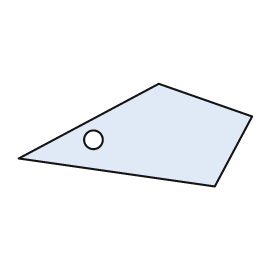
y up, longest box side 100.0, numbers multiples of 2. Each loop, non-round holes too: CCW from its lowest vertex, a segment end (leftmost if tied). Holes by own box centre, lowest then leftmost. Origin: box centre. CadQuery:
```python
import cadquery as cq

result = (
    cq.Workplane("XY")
    .moveTo(34.0, -22.0)
    .lineTo(50.0, 8.0)
    .lineTo(10.0, 22.0)
    .lineTo(-50.0, -10.0)
    .close()
    .moveTo(-18.0, -2.0)
    .circle(4.0)
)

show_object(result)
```